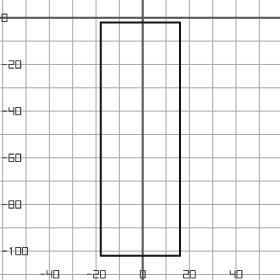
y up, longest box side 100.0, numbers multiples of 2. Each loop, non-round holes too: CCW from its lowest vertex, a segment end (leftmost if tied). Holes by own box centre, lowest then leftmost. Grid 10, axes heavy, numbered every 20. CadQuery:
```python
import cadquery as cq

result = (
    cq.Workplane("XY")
    .moveTo(-18.0, -102.0)
    .lineTo(16.0, -102.0)
    .lineTo(16.0, -2.0)
    .lineTo(-18.0, -2.0)
    .close()
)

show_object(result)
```